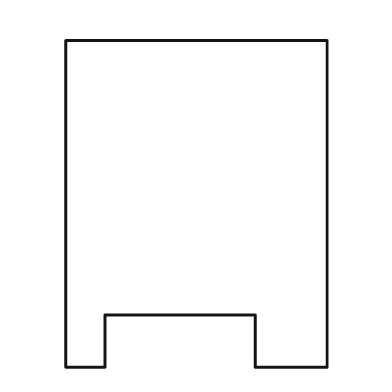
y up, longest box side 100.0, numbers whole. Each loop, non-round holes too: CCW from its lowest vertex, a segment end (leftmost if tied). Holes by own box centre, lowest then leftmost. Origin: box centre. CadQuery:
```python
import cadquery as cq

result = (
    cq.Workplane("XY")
    .moveTo(-40.0, -50.0)
    .lineTo(-28.0, -50.0)
    .lineTo(-28.0, -34.0)
    .lineTo(18.0, -34.0)
    .lineTo(18.0, -50.0)
    .lineTo(40.0, -50.0)
    .lineTo(40.0, 50.0)
    .lineTo(-40.0, 50.0)
    .close()
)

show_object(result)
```